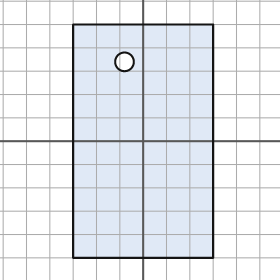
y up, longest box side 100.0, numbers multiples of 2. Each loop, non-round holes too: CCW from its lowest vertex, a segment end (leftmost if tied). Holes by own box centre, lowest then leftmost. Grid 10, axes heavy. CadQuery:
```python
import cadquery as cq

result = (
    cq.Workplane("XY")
    .moveTo(-30.0, -50.0)
    .lineTo(30.0, -50.0)
    .lineTo(30.0, 50.0)
    .lineTo(-30.0, 50.0)
    .close()
    .moveTo(-8.0, 34.0)
    .circle(4.0)
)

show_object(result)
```